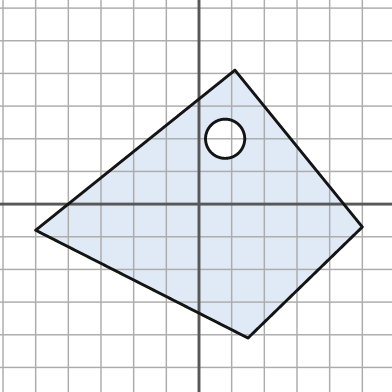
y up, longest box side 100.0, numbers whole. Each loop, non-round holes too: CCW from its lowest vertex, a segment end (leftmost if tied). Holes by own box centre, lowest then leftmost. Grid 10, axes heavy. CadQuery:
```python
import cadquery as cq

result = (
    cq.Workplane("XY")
    .moveTo(15.0, -41.0)
    .lineTo(50.0, -7.0)
    .lineTo(11.0, 41.0)
    .lineTo(-50.0, -8.0)
    .close()
    .moveTo(8.0, 20.0)
    .circle(6.0)
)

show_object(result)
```